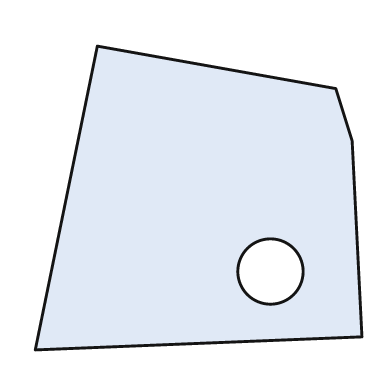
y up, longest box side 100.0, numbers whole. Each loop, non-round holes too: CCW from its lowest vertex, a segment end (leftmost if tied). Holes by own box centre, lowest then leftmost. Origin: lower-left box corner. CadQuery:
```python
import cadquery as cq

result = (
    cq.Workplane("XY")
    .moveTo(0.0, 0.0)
    .lineTo(100.0, 4.0)
    .lineTo(97.0, 64.0)
    .lineTo(92.0, 80.0)
    .lineTo(19.0, 93.0)
    .close()
    .moveTo(72.0, 24.0)
    .circle(10.0)
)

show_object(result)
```